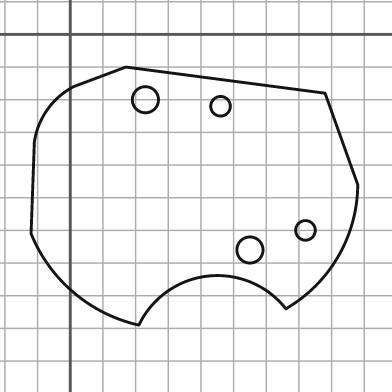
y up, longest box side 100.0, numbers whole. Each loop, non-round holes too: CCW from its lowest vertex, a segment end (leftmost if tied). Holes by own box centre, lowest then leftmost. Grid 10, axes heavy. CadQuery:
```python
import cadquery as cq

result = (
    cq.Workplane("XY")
    .moveTo(21.0, -89.0)
    .threePointArc((42.0, -74.0), (66.0, -84.0))
    .threePointArc((82.0, -68.0), (88.0, -46.0))
    .lineTo(78.0, -18.0)
    .lineTo(17.0, -10.0)
    .lineTo(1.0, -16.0)
    .threePointArc((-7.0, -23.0), (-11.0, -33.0))
    .lineTo(-12.0, -61.0)
    .threePointArc((1.0, -79.0), (21.0, -89.0))
    .close()
    .moveTo(55.0, -66.0)
    .circle(4.0)
    .moveTo(72.0, -60.0)
    .circle(3.0)
    .moveTo(46.0, -22.0)
    .circle(3.0)
    .moveTo(23.0, -20.0)
    .circle(4.0)
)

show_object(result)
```